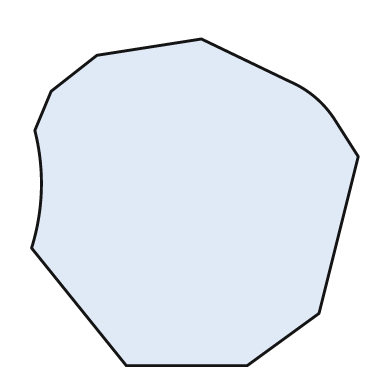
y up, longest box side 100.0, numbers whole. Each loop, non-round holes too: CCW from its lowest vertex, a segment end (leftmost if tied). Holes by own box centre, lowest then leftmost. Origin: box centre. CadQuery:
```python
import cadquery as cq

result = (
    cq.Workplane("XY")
    .moveTo(-21.0, -50.0)
    .lineTo(16.0, -50.0)
    .lineTo(38.0, -34.0)
    .lineTo(50.0, 14.0)
    .lineTo(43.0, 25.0)
    .threePointArc((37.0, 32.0), (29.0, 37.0))
    .lineTo(2.0, 50.0)
    .lineTo(-30.0, 45.0)
    .lineTo(-44.0, 34.0)
    .lineTo(-49.0, 22.0)
    .threePointArc((-47.0, 4.0), (-50.0, -14.0))
    .close()
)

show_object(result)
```